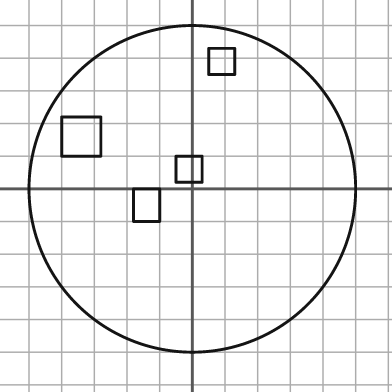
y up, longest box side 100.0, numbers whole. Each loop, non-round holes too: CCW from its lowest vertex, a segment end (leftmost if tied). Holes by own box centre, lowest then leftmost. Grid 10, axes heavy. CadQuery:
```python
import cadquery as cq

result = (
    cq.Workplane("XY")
    .moveTo(0.0, 0.0)
    .circle(50.0)
    .moveTo(-18.0, -10.0)
    .lineTo(-10.0, -10.0)
    .lineTo(-10.0, 0.0)
    .lineTo(-18.0, 0.0)
    .close()
    .moveTo(-5.0, 2.0)
    .lineTo(3.0, 2.0)
    .lineTo(3.0, 10.0)
    .lineTo(-5.0, 10.0)
    .close()
    .moveTo(-40.0, 10.0)
    .lineTo(-28.0, 10.0)
    .lineTo(-28.0, 22.0)
    .lineTo(-40.0, 22.0)
    .close()
    .moveTo(5.0, 35.0)
    .lineTo(13.0, 35.0)
    .lineTo(13.0, 43.0)
    .lineTo(5.0, 43.0)
    .close()
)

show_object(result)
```